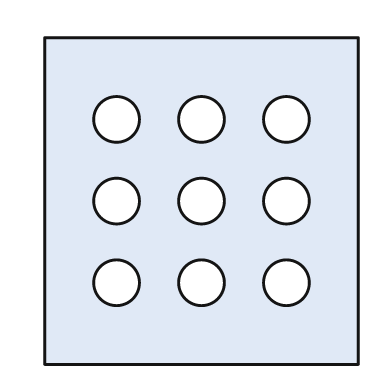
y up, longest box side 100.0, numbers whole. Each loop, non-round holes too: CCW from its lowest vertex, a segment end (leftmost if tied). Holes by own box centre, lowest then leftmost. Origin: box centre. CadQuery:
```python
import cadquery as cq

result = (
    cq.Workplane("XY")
    .moveTo(-48.0, -50.0)
    .lineTo(48.0, -50.0)
    .lineTo(48.0, 50.0)
    .lineTo(-48.0, 50.0)
    .close()
    .moveTo(-26.0, -25.0)
    .circle(7.0)
    .moveTo(0.0, -25.0)
    .circle(7.0)
    .moveTo(26.0, -25.0)
    .circle(7.0)
    .moveTo(-26.0, 0.0)
    .circle(7.0)
    .moveTo(0.0, 0.0)
    .circle(7.0)
    .moveTo(26.0, 0.0)
    .circle(7.0)
    .moveTo(-26.0, 25.0)
    .circle(7.0)
    .moveTo(0.0, 25.0)
    .circle(7.0)
    .moveTo(26.0, 25.0)
    .circle(7.0)
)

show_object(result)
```